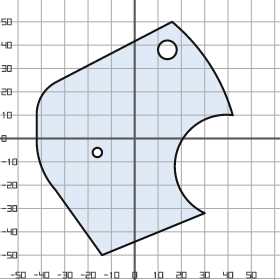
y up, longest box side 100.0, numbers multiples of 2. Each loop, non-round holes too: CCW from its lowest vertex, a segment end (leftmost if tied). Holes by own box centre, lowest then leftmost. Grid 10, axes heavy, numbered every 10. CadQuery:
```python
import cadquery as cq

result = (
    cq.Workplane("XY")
    .moveTo(-14.0, -50.0)
    .lineTo(30.0, -32.0)
    .threePointArc((18.0, -6.0), (42.0, 10.0))
    .threePointArc((32.0, 32.0), (16.0, 50.0))
    .lineTo(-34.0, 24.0)
    .threePointArc((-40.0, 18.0), (-42.0, 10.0))
    .lineTo(-42.0, 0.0)
    .threePointArc((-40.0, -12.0), (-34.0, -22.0))
    .close()
    .moveTo(-16.0, -6.0)
    .circle(2.0)
    .moveTo(14.0, 38.0)
    .circle(4.0)
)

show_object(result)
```